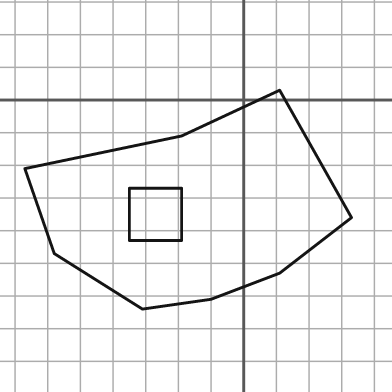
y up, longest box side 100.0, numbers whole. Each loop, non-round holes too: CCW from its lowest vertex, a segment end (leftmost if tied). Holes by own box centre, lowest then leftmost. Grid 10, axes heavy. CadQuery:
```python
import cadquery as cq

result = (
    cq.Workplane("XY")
    .moveTo(-31.0, -64.0)
    .lineTo(-10.0, -61.0)
    .lineTo(11.0, -53.0)
    .lineTo(33.0, -36.0)
    .lineTo(11.0, 3.0)
    .lineTo(-19.0, -11.0)
    .lineTo(-67.0, -21.0)
    .lineTo(-58.0, -47.0)
    .close()
    .moveTo(-35.0, -43.0)
    .lineTo(-19.0, -43.0)
    .lineTo(-19.0, -27.0)
    .lineTo(-35.0, -27.0)
    .close()
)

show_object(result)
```